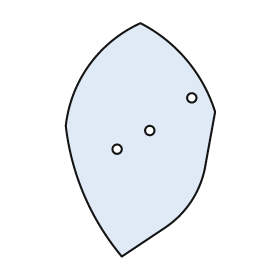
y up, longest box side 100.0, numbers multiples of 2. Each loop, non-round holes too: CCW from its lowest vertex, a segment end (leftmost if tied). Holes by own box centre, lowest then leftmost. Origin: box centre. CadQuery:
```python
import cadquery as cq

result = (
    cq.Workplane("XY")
    .moveTo(-8.0, -50.0)
    .lineTo(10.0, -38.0)
    .threePointArc((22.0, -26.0), (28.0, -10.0))
    .lineTo(32.0, 12.0)
    .threePointArc((20.0, 34.0), (0.0, 50.0))
    .threePointArc((-22.0, 32.0), (-32.0, 6.0))
    .threePointArc((-24.0, -24.0), (-8.0, -50.0))
    .close()
    .moveTo(-10.0, -4.0)
    .circle(2.0)
    .moveTo(4.0, 4.0)
    .circle(2.0)
    .moveTo(22.0, 18.0)
    .circle(2.0)
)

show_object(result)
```